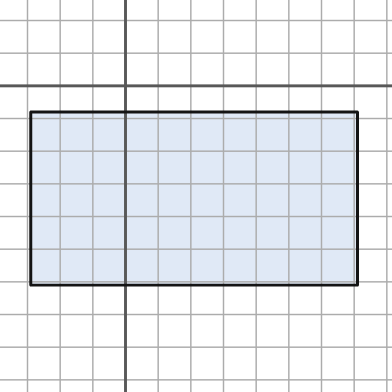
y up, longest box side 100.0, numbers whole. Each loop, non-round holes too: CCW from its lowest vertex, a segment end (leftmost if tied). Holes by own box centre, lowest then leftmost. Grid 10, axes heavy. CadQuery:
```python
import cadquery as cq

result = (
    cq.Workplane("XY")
    .moveTo(-29.0, -61.0)
    .lineTo(71.0, -61.0)
    .lineTo(71.0, -8.0)
    .lineTo(-29.0, -8.0)
    .close()
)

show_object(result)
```